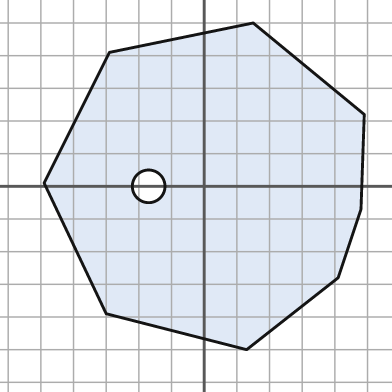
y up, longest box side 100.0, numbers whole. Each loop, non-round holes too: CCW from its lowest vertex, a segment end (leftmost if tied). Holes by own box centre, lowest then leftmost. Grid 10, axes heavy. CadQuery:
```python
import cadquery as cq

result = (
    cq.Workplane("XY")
    .moveTo(13.0, -50.0)
    .lineTo(41.0, -28.0)
    .lineTo(48.0, -7.0)
    .lineTo(49.0, 22.0)
    .lineTo(15.0, 50.0)
    .lineTo(-29.0, 41.0)
    .lineTo(-49.0, 1.0)
    .lineTo(-30.0, -39.0)
    .close()
    .moveTo(-17.0, 0.0)
    .circle(5.0)
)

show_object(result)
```